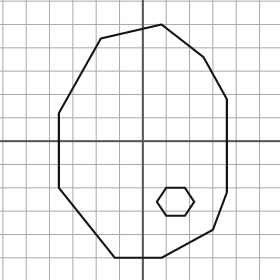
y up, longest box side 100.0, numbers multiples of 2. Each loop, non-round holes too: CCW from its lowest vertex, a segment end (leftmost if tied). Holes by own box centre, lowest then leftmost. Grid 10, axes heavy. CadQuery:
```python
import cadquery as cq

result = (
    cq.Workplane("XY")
    .moveTo(-12.0, -50.0)
    .lineTo(8.0, -50.0)
    .lineTo(30.0, -38.0)
    .lineTo(36.0, -22.0)
    .lineTo(36.0, 18.0)
    .lineTo(26.0, 36.0)
    .lineTo(8.0, 50.0)
    .lineTo(-18.0, 44.0)
    .lineTo(-36.0, 12.0)
    .lineTo(-36.0, -20.0)
    .close()
    .moveTo(10.0, -32.0)
    .lineTo(18.0, -32.0)
    .lineTo(22.0, -26.0)
    .lineTo(18.0, -20.0)
    .lineTo(10.0, -20.0)
    .lineTo(6.0, -26.0)
    .close()
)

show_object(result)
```